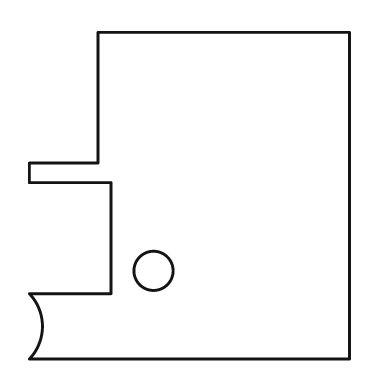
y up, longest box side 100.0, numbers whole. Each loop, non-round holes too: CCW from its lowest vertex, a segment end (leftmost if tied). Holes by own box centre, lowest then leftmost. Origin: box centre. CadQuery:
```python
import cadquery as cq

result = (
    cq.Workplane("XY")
    .moveTo(-49.0, -50.0)
    .lineTo(49.0, -50.0)
    .lineTo(49.0, 50.0)
    .lineTo(-28.0, 50.0)
    .lineTo(-28.0, 10.0)
    .lineTo(-49.0, 10.0)
    .lineTo(-49.0, 4.0)
    .lineTo(-24.0, 4.0)
    .lineTo(-24.0, -30.0)
    .lineTo(-49.0, -30.0)
    .threePointArc((-45.0, -40.0), (-49.0, -50.0))
    .close()
    .moveTo(-11.0, -23.0)
    .circle(6.0)
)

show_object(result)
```